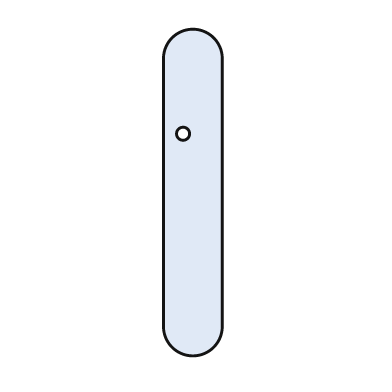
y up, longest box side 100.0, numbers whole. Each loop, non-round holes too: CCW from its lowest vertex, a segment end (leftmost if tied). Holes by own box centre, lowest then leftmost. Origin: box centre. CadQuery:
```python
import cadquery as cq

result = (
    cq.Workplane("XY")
    .moveTo(-9.0, -41.0)
    .threePointArc((0.0, -50.0), (9.0, -41.0))
    .lineTo(9.0, 41.0)
    .threePointArc((0.0, 50.0), (-9.0, 41.0))
    .close()
    .moveTo(-3.0, 18.0)
    .circle(2.0)
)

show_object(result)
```